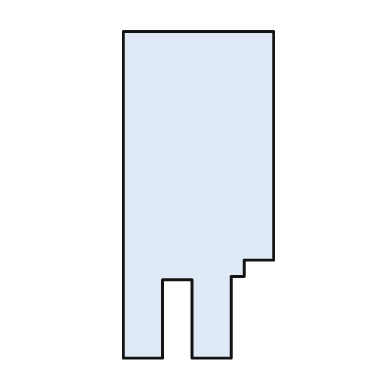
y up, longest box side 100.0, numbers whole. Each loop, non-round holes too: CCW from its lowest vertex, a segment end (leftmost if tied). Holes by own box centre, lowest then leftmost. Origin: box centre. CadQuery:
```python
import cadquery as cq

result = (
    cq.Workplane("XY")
    .moveTo(-23.0, -50.0)
    .lineTo(-11.0, -50.0)
    .lineTo(-11.0, -26.0)
    .lineTo(-2.0, -26.0)
    .lineTo(-2.0, -50.0)
    .lineTo(10.0, -50.0)
    .lineTo(10.0, -25.0)
    .lineTo(14.0, -25.0)
    .lineTo(14.0, -20.0)
    .lineTo(23.0, -20.0)
    .lineTo(23.0, 50.0)
    .lineTo(-23.0, 50.0)
    .close()
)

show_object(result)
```